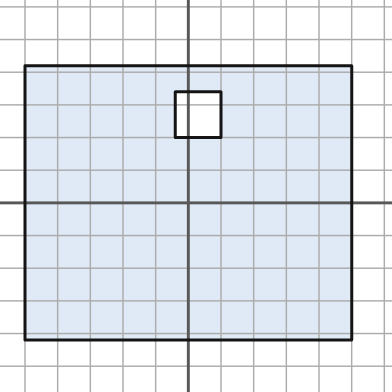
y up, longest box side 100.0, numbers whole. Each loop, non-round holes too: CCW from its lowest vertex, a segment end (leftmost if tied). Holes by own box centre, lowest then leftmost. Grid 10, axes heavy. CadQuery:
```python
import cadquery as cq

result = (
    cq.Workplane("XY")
    .moveTo(-50.0, -42.0)
    .lineTo(50.0, -42.0)
    .lineTo(50.0, 42.0)
    .lineTo(-50.0, 42.0)
    .close()
    .moveTo(-4.0, 20.0)
    .lineTo(10.0, 20.0)
    .lineTo(10.0, 34.0)
    .lineTo(-4.0, 34.0)
    .close()
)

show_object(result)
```